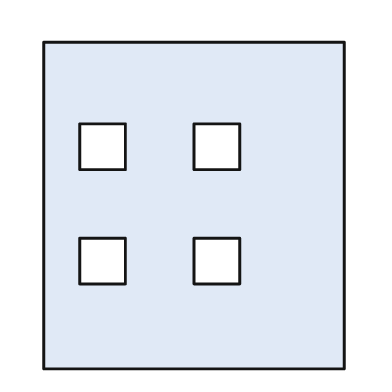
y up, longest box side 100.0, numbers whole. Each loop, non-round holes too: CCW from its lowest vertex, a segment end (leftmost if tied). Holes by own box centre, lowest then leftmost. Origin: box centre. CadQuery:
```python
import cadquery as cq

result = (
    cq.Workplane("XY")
    .moveTo(-46.0, -50.0)
    .lineTo(46.0, -50.0)
    .lineTo(46.0, 50.0)
    .lineTo(-46.0, 50.0)
    .close()
    .moveTo(-35.0, -24.0)
    .lineTo(-21.0, -24.0)
    .lineTo(-21.0, -10.0)
    .lineTo(-35.0, -10.0)
    .close()
    .moveTo(0.0, -24.0)
    .lineTo(14.0, -24.0)
    .lineTo(14.0, -10.0)
    .lineTo(0.0, -10.0)
    .close()
    .moveTo(-35.0, 11.0)
    .lineTo(-21.0, 11.0)
    .lineTo(-21.0, 25.0)
    .lineTo(-35.0, 25.0)
    .close()
    .moveTo(0.0, 11.0)
    .lineTo(14.0, 11.0)
    .lineTo(14.0, 25.0)
    .lineTo(0.0, 25.0)
    .close()
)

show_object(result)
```